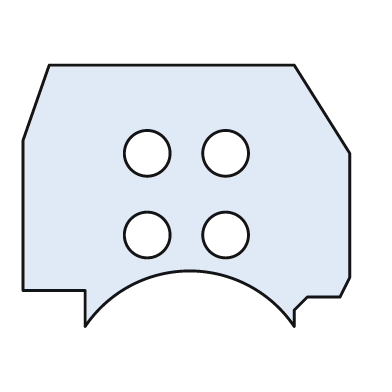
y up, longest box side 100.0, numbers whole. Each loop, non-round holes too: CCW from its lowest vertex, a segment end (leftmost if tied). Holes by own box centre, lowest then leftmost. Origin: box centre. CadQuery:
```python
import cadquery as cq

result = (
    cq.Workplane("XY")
    .moveTo(-31.0, -40.0)
    .threePointArc((1.0, -23.0), (33.0, -40.0))
    .lineTo(33.0, -35.0)
    .lineTo(37.0, -31.0)
    .lineTo(47.0, -31.0)
    .lineTo(50.0, -25.0)
    .lineTo(50.0, 13.0)
    .lineTo(33.0, 40.0)
    .lineTo(-42.0, 40.0)
    .lineTo(-50.0, 17.0)
    .lineTo(-50.0, -29.0)
    .lineTo(-31.0, -29.0)
    .close()
    .moveTo(-12.0, -12.0)
    .circle(7.0)
    .moveTo(12.0, -12.0)
    .circle(7.0)
    .moveTo(-12.0, 13.0)
    .circle(7.0)
    .moveTo(12.0, 13.0)
    .circle(7.0)
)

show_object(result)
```